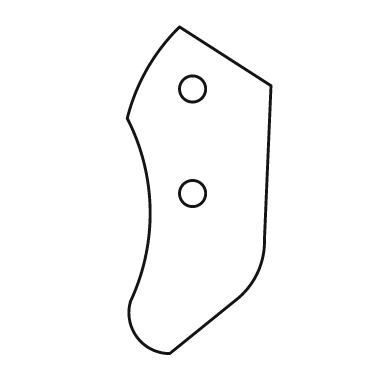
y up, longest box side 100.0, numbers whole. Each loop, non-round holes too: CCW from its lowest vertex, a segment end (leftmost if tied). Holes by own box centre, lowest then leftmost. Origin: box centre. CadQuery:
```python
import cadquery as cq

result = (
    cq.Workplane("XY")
    .moveTo(-9.0, -50.0)
    .lineTo(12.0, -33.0)
    .threePointArc((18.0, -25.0), (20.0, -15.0))
    .lineTo(22.0, 32.0)
    .lineTo(-6.0, 50.0)
    .threePointArc((-16.0, 37.0), (-22.0, 22.0))
    .threePointArc((-15.0, -6.0), (-21.0, -34.0))
    .threePointArc((-19.0, -45.0), (-9.0, -50.0))
    .close()
    .moveTo(-2.0, -1.0)
    .circle(4.0)
    .moveTo(-2.0, 31.0)
    .circle(4.0)
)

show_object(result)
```